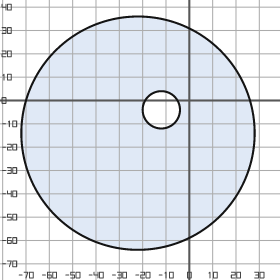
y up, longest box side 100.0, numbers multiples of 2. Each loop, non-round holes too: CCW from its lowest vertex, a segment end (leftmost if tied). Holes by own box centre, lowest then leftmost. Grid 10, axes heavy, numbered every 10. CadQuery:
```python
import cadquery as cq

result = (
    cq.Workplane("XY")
    .moveTo(-22.0, -14.0)
    .circle(50.0)
    .moveTo(-12.0, -4.0)
    .circle(8.0)
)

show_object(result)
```